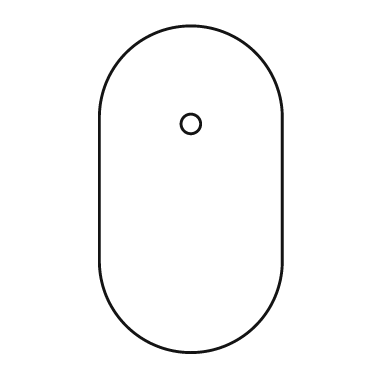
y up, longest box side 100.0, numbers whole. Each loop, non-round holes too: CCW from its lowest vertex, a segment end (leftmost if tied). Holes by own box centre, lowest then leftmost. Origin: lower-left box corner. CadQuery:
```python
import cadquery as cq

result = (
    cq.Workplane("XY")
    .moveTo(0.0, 28.0)
    .threePointArc((28.0, 0.0), (56.0, 28.0))
    .lineTo(56.0, 72.0)
    .threePointArc((28.0, 100.0), (0.0, 72.0))
    .close()
    .moveTo(28.0, 70.0)
    .circle(3.0)
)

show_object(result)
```